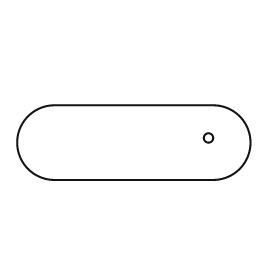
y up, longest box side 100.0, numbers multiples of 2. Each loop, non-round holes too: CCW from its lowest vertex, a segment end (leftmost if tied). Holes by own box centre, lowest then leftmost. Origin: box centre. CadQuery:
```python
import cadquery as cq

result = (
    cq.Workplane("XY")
    .moveTo(-34.0, -16.0)
    .lineTo(34.0, -16.0)
    .threePointArc((50.0, 0.0), (34.0, 16.0))
    .lineTo(-34.0, 16.0)
    .threePointArc((-50.0, 0.0), (-34.0, -16.0))
    .close()
    .moveTo(32.0, 2.0)
    .circle(2.0)
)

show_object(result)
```